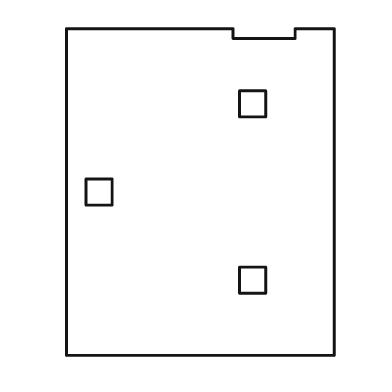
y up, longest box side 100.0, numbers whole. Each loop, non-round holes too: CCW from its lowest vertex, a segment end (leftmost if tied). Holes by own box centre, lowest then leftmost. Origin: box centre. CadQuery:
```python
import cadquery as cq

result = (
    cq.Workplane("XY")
    .moveTo(-41.0, -50.0)
    .lineTo(41.0, -50.0)
    .lineTo(41.0, 50.0)
    .lineTo(29.0, 50.0)
    .lineTo(29.0, 47.0)
    .lineTo(10.0, 47.0)
    .lineTo(10.0, 50.0)
    .lineTo(-41.0, 50.0)
    .close()
    .moveTo(12.0, -31.0)
    .lineTo(20.0, -31.0)
    .lineTo(20.0, -23.0)
    .lineTo(12.0, -23.0)
    .close()
    .moveTo(-35.0, -4.0)
    .lineTo(-27.0, -4.0)
    .lineTo(-27.0, 4.0)
    .lineTo(-35.0, 4.0)
    .close()
    .moveTo(12.0, 23.0)
    .lineTo(20.0, 23.0)
    .lineTo(20.0, 31.0)
    .lineTo(12.0, 31.0)
    .close()
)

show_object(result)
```